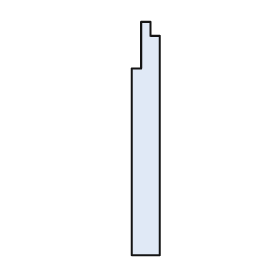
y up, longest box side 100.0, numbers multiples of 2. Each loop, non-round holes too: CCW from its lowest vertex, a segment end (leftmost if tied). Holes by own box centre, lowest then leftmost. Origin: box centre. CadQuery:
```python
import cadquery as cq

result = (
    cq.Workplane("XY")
    .moveTo(-6.0, -50.0)
    .lineTo(6.0, -50.0)
    .lineTo(6.0, 44.0)
    .lineTo(2.0, 44.0)
    .lineTo(2.0, 50.0)
    .lineTo(-2.0, 50.0)
    .lineTo(-2.0, 30.0)
    .lineTo(-6.0, 30.0)
    .close()
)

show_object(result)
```